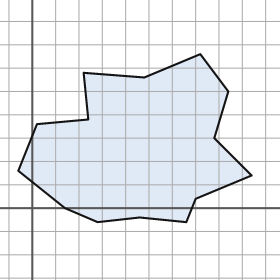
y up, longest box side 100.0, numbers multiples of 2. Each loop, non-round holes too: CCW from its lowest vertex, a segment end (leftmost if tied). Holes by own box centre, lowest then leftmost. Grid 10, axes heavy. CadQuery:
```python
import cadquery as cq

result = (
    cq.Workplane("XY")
    .moveTo(28.0, -6.0)
    .lineTo(46.0, -4.0)
    .lineTo(66.0, -6.0)
    .lineTo(70.0, 4.0)
    .lineTo(94.0, 14.0)
    .lineTo(78.0, 30.0)
    .lineTo(84.0, 50.0)
    .lineTo(72.0, 66.0)
    .lineTo(48.0, 56.0)
    .lineTo(22.0, 58.0)
    .lineTo(24.0, 38.0)
    .lineTo(2.0, 36.0)
    .lineTo(-6.0, 16.0)
    .lineTo(14.0, 0.0)
    .close()
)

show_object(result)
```